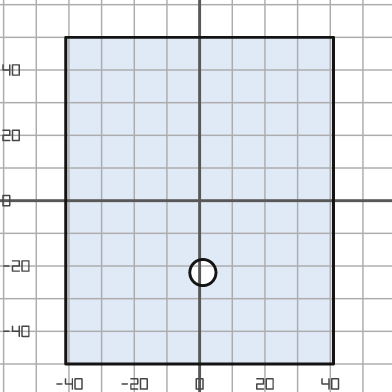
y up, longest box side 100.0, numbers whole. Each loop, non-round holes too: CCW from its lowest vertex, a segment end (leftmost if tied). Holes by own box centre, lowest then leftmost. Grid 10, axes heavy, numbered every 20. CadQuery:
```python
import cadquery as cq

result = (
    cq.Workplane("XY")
    .moveTo(-41.0, -50.0)
    .lineTo(41.0, -50.0)
    .lineTo(41.0, 50.0)
    .lineTo(-41.0, 50.0)
    .close()
    .moveTo(1.0, -22.0)
    .circle(4.0)
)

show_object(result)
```